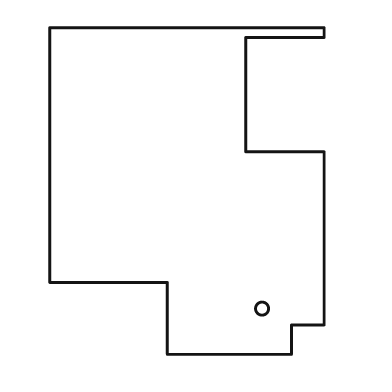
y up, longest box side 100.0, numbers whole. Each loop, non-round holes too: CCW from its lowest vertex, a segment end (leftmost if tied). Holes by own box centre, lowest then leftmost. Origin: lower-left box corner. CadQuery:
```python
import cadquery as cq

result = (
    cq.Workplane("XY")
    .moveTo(36.0, 0.0)
    .lineTo(74.0, 0.0)
    .lineTo(74.0, 9.0)
    .lineTo(84.0, 9.0)
    .lineTo(84.0, 62.0)
    .lineTo(60.0, 62.0)
    .lineTo(60.0, 97.0)
    .lineTo(84.0, 97.0)
    .lineTo(84.0, 100.0)
    .lineTo(0.0, 100.0)
    .lineTo(0.0, 22.0)
    .lineTo(36.0, 22.0)
    .close()
    .moveTo(65.0, 14.0)
    .circle(2.0)
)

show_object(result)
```